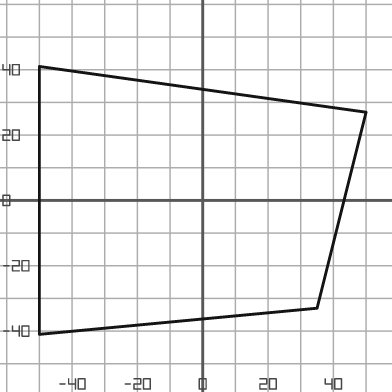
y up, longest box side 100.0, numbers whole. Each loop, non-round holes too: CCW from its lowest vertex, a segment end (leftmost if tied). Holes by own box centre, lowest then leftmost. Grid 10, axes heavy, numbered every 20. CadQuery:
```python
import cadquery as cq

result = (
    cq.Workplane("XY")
    .moveTo(-50.0, -41.0)
    .lineTo(35.0, -33.0)
    .lineTo(50.0, 27.0)
    .lineTo(-50.0, 41.0)
    .close()
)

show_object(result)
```